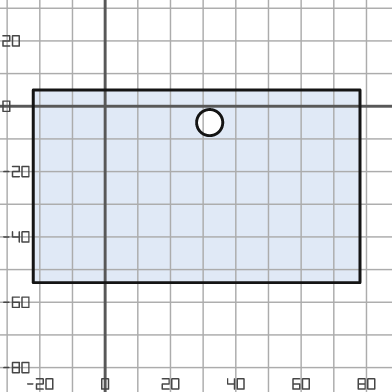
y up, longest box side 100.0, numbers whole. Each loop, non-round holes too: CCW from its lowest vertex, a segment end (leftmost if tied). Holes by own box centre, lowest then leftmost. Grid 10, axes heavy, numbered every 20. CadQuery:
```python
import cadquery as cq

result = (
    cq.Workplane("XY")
    .moveTo(-22.0, -54.0)
    .lineTo(78.0, -54.0)
    .lineTo(78.0, 5.0)
    .lineTo(-22.0, 5.0)
    .close()
    .moveTo(32.0, -5.0)
    .circle(4.0)
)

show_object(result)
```